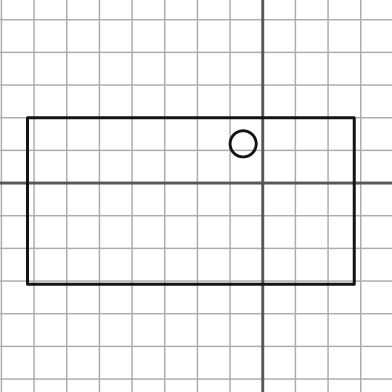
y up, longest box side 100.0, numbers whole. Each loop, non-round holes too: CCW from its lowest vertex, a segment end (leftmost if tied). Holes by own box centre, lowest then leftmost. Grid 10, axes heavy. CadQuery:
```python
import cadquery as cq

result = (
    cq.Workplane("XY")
    .moveTo(-72.0, -31.0)
    .lineTo(28.0, -31.0)
    .lineTo(28.0, 20.0)
    .lineTo(-72.0, 20.0)
    .close()
    .moveTo(-6.0, 12.0)
    .circle(4.0)
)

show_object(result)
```